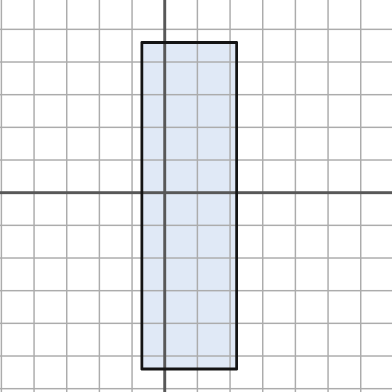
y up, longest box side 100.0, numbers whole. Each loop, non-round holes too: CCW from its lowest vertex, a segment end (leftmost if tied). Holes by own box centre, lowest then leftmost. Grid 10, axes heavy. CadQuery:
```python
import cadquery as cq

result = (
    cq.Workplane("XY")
    .moveTo(-7.0, -54.0)
    .lineTo(22.0, -54.0)
    .lineTo(22.0, 46.0)
    .lineTo(-7.0, 46.0)
    .close()
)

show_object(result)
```